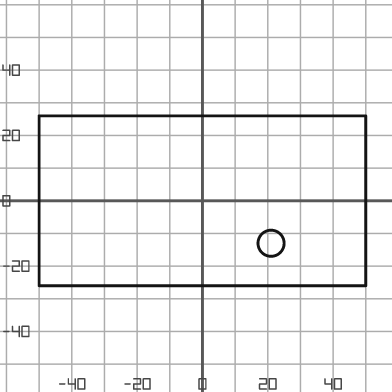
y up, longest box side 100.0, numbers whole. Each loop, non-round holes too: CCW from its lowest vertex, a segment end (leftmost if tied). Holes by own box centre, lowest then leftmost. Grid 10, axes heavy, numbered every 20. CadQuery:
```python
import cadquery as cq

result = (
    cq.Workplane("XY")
    .moveTo(-50.0, -26.0)
    .lineTo(50.0, -26.0)
    .lineTo(50.0, 26.0)
    .lineTo(-50.0, 26.0)
    .close()
    .moveTo(21.0, -13.0)
    .circle(4.0)
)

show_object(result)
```